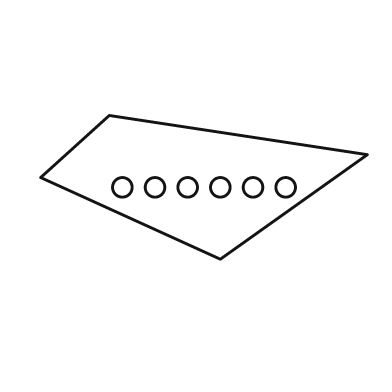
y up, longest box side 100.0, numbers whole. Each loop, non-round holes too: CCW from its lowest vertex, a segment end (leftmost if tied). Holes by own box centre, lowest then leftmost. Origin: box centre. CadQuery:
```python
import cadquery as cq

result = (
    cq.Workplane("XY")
    .moveTo(5.0, -22.0)
    .lineTo(50.0, 10.0)
    .lineTo(-29.0, 22.0)
    .lineTo(-50.0, 3.0)
    .close()
    .moveTo(-25.0, 0.0)
    .circle(3.0)
    .moveTo(-15.0, 0.0)
    .circle(3.0)
    .moveTo(-5.0, 0.0)
    .circle(3.0)
    .moveTo(5.0, 0.0)
    .circle(3.0)
    .moveTo(15.0, 0.0)
    .circle(3.0)
    .moveTo(25.0, 0.0)
    .circle(3.0)
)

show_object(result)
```